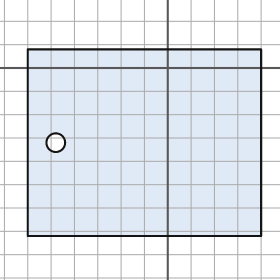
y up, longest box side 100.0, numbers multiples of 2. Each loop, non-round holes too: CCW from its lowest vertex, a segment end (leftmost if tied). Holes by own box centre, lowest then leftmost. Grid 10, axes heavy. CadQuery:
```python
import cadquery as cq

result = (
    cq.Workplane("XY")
    .moveTo(-60.0, -72.0)
    .lineTo(40.0, -72.0)
    .lineTo(40.0, 8.0)
    .lineTo(-60.0, 8.0)
    .close()
    .moveTo(-48.0, -32.0)
    .circle(4.0)
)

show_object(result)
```